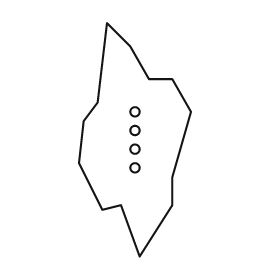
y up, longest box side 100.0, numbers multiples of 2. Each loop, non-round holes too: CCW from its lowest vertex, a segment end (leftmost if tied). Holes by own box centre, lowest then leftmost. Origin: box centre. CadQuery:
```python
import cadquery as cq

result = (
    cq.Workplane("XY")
    .moveTo(2.0, -50.0)
    .lineTo(16.0, -28.0)
    .lineTo(16.0, -16.0)
    .lineTo(24.0, 12.0)
    .lineTo(16.0, 26.0)
    .lineTo(6.0, 26.0)
    .lineTo(-2.0, 40.0)
    .lineTo(-12.0, 50.0)
    .lineTo(-16.0, 16.0)
    .lineTo(-22.0, 8.0)
    .lineTo(-24.0, -10.0)
    .lineTo(-14.0, -30.0)
    .lineTo(-6.0, -28.0)
    .close()
    .moveTo(0.0, -12.0)
    .circle(2.0)
    .moveTo(0.0, -4.0)
    .circle(2.0)
    .moveTo(0.0, 4.0)
    .circle(2.0)
    .moveTo(0.0, 12.0)
    .circle(2.0)
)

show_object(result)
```